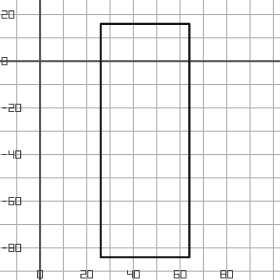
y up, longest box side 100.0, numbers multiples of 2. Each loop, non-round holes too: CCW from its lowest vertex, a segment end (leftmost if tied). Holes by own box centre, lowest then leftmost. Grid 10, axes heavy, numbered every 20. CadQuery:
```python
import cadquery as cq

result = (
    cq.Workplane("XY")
    .moveTo(26.0, -84.0)
    .lineTo(64.0, -84.0)
    .lineTo(64.0, 16.0)
    .lineTo(26.0, 16.0)
    .close()
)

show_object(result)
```